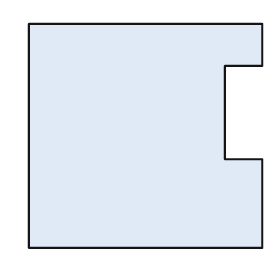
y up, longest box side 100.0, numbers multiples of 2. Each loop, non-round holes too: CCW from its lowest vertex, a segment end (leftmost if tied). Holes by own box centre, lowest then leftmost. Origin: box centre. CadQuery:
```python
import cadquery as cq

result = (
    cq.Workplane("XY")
    .moveTo(-50.0, -48.0)
    .lineTo(50.0, -48.0)
    .lineTo(50.0, -10.0)
    .lineTo(34.0, -10.0)
    .lineTo(34.0, 30.0)
    .lineTo(50.0, 30.0)
    .lineTo(50.0, 48.0)
    .lineTo(-50.0, 48.0)
    .close()
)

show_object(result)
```